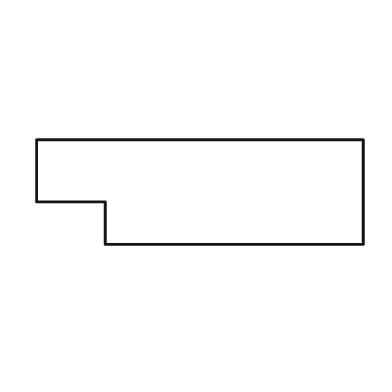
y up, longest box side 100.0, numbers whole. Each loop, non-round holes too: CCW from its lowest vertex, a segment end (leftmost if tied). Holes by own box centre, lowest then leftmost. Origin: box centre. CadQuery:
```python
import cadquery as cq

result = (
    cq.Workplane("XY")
    .moveTo(-29.0, -16.0)
    .lineTo(50.0, -16.0)
    .lineTo(50.0, 16.0)
    .lineTo(-50.0, 16.0)
    .lineTo(-50.0, -3.0)
    .lineTo(-29.0, -3.0)
    .close()
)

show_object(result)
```